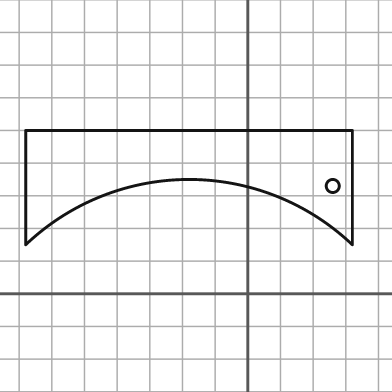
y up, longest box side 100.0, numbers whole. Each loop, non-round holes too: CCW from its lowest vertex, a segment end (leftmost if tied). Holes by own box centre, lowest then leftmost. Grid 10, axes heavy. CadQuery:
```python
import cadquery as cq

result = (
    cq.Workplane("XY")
    .moveTo(-68.0, 15.0)
    .threePointArc((-18.0, 35.0), (32.0, 15.0))
    .lineTo(32.0, 50.0)
    .lineTo(-68.0, 50.0)
    .close()
    .moveTo(26.0, 33.0)
    .circle(2.0)
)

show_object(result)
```